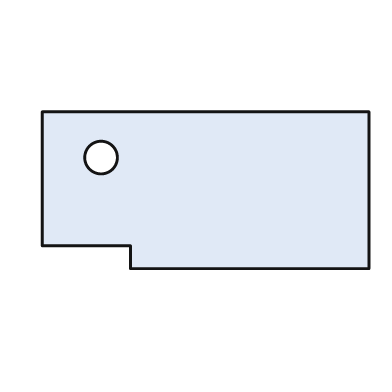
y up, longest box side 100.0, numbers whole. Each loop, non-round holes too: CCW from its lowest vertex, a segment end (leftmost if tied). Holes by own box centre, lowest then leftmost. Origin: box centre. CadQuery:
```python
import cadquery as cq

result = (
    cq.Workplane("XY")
    .moveTo(-23.0, -24.0)
    .lineTo(50.0, -24.0)
    .lineTo(50.0, 24.0)
    .lineTo(-50.0, 24.0)
    .lineTo(-50.0, -17.0)
    .lineTo(-23.0, -17.0)
    .close()
    .moveTo(-32.0, 10.0)
    .circle(5.0)
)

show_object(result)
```